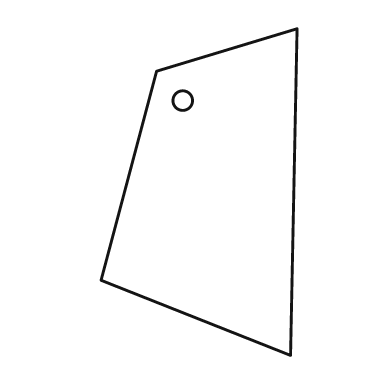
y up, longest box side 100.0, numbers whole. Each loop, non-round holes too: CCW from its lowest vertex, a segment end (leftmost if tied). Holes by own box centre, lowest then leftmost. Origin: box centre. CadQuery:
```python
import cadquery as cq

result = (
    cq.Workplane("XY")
    .moveTo(28.0, -50.0)
    .lineTo(30.0, 50.0)
    .lineTo(-13.0, 37.0)
    .lineTo(-30.0, -27.0)
    .close()
    .moveTo(-5.0, 28.0)
    .circle(3.0)
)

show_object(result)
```